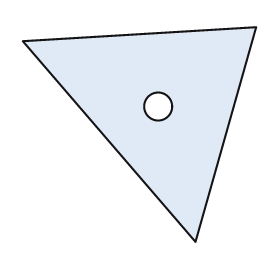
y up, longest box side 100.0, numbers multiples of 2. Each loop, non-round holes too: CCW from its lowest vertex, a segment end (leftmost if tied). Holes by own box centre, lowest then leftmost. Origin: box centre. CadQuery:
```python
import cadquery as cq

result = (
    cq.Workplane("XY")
    .moveTo(24.0, -46.0)
    .lineTo(50.0, 46.0)
    .lineTo(-50.0, 40.0)
    .close()
    .moveTo(8.0, 12.0)
    .circle(6.0)
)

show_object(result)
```